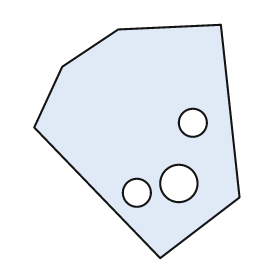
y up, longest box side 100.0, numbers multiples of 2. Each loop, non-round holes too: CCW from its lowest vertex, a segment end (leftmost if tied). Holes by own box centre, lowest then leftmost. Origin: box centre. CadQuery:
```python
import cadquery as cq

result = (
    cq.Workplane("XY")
    .moveTo(10.0, -50.0)
    .lineTo(44.0, -24.0)
    .lineTo(36.0, 50.0)
    .lineTo(-8.0, 48.0)
    .lineTo(-32.0, 32.0)
    .lineTo(-44.0, 6.0)
    .close()
    .moveTo(0.0, -22.0)
    .circle(6.0)
    .moveTo(18.0, -18.0)
    .circle(8.0)
    .moveTo(24.0, 8.0)
    .circle(6.0)
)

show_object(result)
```